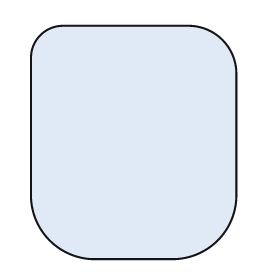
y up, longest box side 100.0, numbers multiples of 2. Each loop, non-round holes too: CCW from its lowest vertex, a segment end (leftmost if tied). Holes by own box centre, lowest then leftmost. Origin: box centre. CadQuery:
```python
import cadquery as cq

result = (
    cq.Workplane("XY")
    .moveTo(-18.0, -50.0)
    .lineTo(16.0, -50.0)
    .threePointArc((36.0, -42.0), (44.0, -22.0))
    .lineTo(44.0, 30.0)
    .threePointArc((38.0, 44.0), (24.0, 50.0))
    .lineTo(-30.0, 50.0)
    .threePointArc((-40.0, 46.0), (-44.0, 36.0))
    .lineTo(-44.0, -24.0)
    .threePointArc((-36.0, -42.0), (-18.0, -50.0))
    .close()
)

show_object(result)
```